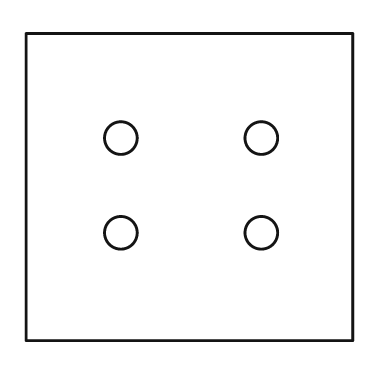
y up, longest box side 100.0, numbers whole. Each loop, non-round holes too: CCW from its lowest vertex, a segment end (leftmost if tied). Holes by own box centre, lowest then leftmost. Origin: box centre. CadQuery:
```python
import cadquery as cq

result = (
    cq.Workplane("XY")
    .moveTo(-50.0, -47.0)
    .lineTo(50.0, -47.0)
    .lineTo(50.0, 47.0)
    .lineTo(-50.0, 47.0)
    .close()
    .moveTo(-21.0, -14.0)
    .circle(5.0)
    .moveTo(22.0, -14.0)
    .circle(5.0)
    .moveTo(-21.0, 15.0)
    .circle(5.0)
    .moveTo(22.0, 15.0)
    .circle(5.0)
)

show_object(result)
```